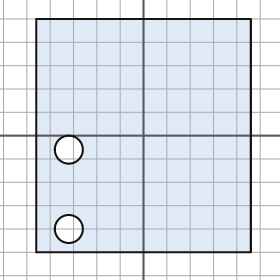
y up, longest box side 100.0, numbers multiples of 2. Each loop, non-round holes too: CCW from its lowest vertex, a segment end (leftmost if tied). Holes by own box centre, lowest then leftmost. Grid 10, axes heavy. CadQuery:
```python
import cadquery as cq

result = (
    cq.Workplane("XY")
    .moveTo(-46.0, -50.0)
    .lineTo(46.0, -50.0)
    .lineTo(46.0, 50.0)
    .lineTo(-46.0, 50.0)
    .close()
    .moveTo(-32.0, -40.0)
    .circle(6.0)
    .moveTo(-32.0, -6.0)
    .circle(6.0)
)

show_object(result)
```